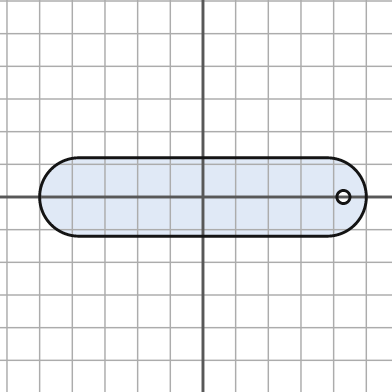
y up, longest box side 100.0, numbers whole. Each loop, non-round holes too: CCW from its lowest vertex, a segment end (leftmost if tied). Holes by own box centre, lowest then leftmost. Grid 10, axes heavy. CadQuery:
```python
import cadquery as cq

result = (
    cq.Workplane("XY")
    .moveTo(-38.0, -12.0)
    .lineTo(38.0, -12.0)
    .threePointArc((50.0, 0.0), (38.0, 12.0))
    .lineTo(-38.0, 12.0)
    .threePointArc((-50.0, 0.0), (-38.0, -12.0))
    .close()
    .moveTo(43.0, 0.0)
    .circle(2.0)
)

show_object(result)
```